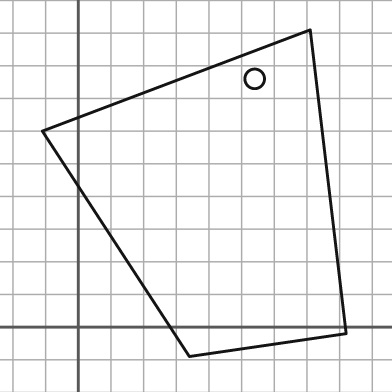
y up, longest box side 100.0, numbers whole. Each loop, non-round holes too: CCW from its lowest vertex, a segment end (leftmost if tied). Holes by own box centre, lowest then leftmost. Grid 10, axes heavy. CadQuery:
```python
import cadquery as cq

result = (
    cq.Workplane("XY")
    .moveTo(34.0, -9.0)
    .lineTo(82.0, -2.0)
    .lineTo(71.0, 91.0)
    .lineTo(-11.0, 60.0)
    .close()
    .moveTo(54.0, 76.0)
    .circle(3.0)
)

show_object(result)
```